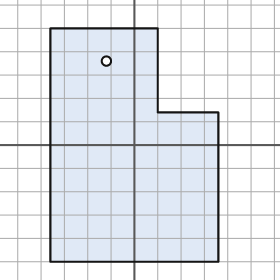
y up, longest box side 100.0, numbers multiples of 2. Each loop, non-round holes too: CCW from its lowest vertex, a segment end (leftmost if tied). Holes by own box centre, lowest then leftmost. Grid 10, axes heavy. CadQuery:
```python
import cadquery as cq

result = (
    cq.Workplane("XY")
    .moveTo(-36.0, -50.0)
    .lineTo(36.0, -50.0)
    .lineTo(36.0, 14.0)
    .lineTo(10.0, 14.0)
    .lineTo(10.0, 50.0)
    .lineTo(-36.0, 50.0)
    .close()
    .moveTo(-12.0, 36.0)
    .circle(2.0)
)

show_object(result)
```